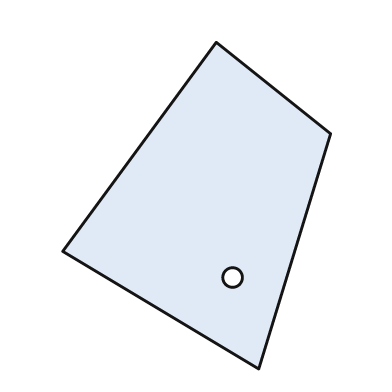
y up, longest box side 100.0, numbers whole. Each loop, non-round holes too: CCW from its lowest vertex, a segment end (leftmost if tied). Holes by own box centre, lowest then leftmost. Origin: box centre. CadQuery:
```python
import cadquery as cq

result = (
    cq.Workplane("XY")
    .moveTo(19.0, -50.0)
    .lineTo(41.0, 22.0)
    .lineTo(6.0, 50.0)
    .lineTo(-41.0, -14.0)
    .close()
    .moveTo(11.0, -22.0)
    .circle(3.0)
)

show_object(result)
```